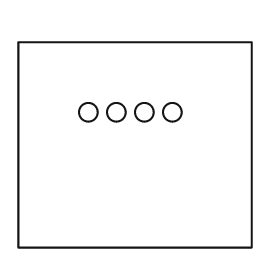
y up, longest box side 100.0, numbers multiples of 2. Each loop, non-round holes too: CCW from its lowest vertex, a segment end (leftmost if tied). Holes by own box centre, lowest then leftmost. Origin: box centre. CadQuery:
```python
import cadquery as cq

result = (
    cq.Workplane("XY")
    .moveTo(-50.0, -44.0)
    .lineTo(50.0, -44.0)
    .lineTo(50.0, 44.0)
    .lineTo(-50.0, 44.0)
    .close()
    .moveTo(-20.0, 14.0)
    .circle(4.0)
    .moveTo(-8.0, 14.0)
    .circle(4.0)
    .moveTo(4.0, 14.0)
    .circle(4.0)
    .moveTo(16.0, 14.0)
    .circle(4.0)
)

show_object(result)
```